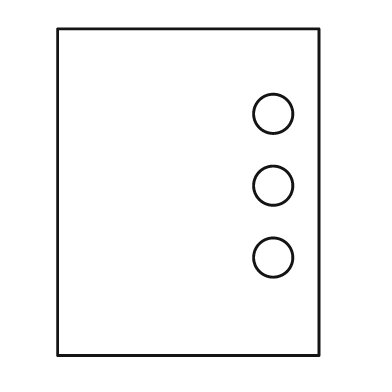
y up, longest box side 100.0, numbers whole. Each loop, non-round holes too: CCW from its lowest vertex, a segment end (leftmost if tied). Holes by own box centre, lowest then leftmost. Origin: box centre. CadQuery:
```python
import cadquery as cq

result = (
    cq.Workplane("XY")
    .moveTo(-40.0, -50.0)
    .lineTo(40.0, -50.0)
    .lineTo(40.0, 50.0)
    .lineTo(-40.0, 50.0)
    .close()
    .moveTo(26.0, -20.0)
    .circle(6.0)
    .moveTo(26.0, 2.0)
    .circle(6.0)
    .moveTo(26.0, 24.0)
    .circle(6.0)
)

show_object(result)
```